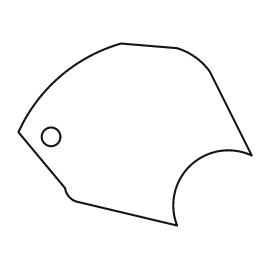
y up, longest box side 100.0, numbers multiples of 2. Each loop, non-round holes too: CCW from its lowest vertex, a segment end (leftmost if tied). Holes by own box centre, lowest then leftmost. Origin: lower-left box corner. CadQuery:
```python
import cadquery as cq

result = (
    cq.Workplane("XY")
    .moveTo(68.0, 0.0)
    .threePointArc((74.0, 26.0), (100.0, 30.0))
    .lineTo(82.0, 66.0)
    .threePointArc((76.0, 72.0), (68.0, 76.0))
    .lineTo(44.0, 78.0)
    .threePointArc((18.0, 64.0), (0.0, 40.0))
    .lineTo(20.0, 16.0)
    .threePointArc((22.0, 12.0), (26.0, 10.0))
    .close()
    .moveTo(14.0, 38.0)
    .circle(4.0)
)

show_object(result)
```